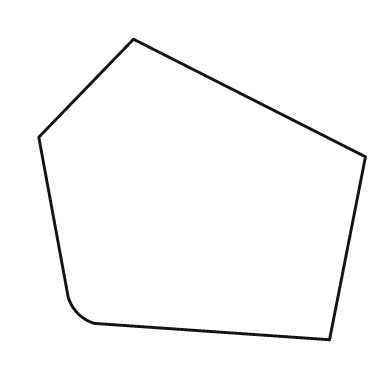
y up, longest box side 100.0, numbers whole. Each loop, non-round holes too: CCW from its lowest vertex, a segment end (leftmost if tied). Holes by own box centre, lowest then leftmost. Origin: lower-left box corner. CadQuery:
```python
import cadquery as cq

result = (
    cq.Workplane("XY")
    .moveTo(89.0, 0.0)
    .lineTo(100.0, 56.0)
    .lineTo(29.0, 92.0)
    .lineTo(0.0, 62.0)
    .lineTo(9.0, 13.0)
    .threePointArc((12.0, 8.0), (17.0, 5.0))
    .close()
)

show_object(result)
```